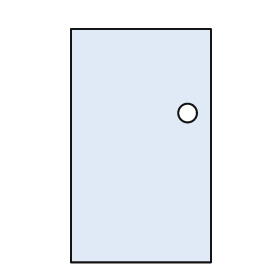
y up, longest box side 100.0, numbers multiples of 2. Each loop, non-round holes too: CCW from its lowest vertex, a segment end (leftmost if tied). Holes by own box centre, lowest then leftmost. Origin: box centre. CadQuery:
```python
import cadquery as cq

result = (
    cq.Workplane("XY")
    .moveTo(-30.0, -50.0)
    .lineTo(30.0, -50.0)
    .lineTo(30.0, 50.0)
    .lineTo(-30.0, 50.0)
    .close()
    .moveTo(20.0, 14.0)
    .circle(4.0)
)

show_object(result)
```